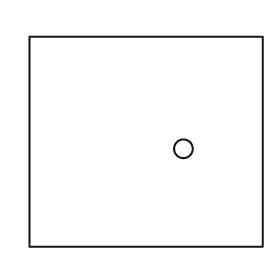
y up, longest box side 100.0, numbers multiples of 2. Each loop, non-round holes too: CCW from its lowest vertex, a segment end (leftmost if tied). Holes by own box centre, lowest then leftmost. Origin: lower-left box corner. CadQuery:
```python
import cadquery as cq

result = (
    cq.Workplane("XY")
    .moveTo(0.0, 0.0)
    .lineTo(100.0, 0.0)
    .lineTo(100.0, 90.0)
    .lineTo(0.0, 90.0)
    .close()
    .moveTo(66.0, 42.0)
    .circle(4.0)
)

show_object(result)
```